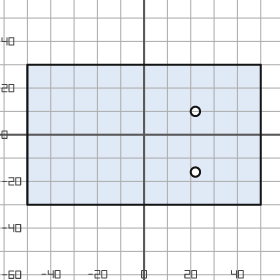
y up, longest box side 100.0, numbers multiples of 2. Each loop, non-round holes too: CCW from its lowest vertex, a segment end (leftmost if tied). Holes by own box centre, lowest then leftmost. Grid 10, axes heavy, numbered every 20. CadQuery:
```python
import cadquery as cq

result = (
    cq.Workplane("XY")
    .moveTo(-50.0, -30.0)
    .lineTo(50.0, -30.0)
    .lineTo(50.0, 30.0)
    .lineTo(-50.0, 30.0)
    .close()
    .moveTo(22.0, -16.0)
    .circle(2.0)
    .moveTo(22.0, 10.0)
    .circle(2.0)
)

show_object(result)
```